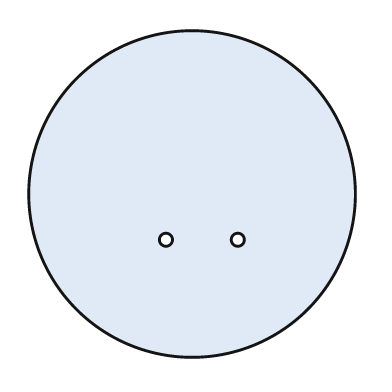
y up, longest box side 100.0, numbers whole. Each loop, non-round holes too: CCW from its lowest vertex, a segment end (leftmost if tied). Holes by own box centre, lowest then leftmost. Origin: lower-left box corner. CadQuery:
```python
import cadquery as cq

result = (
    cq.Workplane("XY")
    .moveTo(50.0, 50.0)
    .circle(50.0)
    .moveTo(42.0, 36.0)
    .circle(2.0)
    .moveTo(64.0, 36.0)
    .circle(2.0)
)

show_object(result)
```